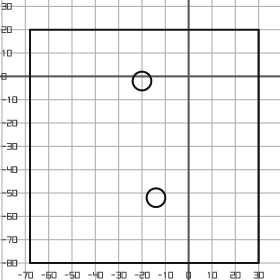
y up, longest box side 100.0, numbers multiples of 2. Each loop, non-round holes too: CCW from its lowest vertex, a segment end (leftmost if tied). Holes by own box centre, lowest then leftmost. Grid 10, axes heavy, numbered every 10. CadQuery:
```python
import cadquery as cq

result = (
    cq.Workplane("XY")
    .moveTo(-68.0, -80.0)
    .lineTo(30.0, -80.0)
    .lineTo(30.0, 20.0)
    .lineTo(-68.0, 20.0)
    .close()
    .moveTo(-14.0, -52.0)
    .circle(4.0)
    .moveTo(-20.0, -2.0)
    .circle(4.0)
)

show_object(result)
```